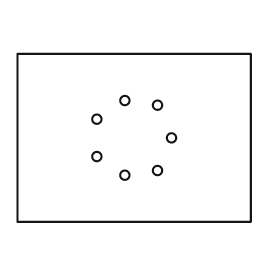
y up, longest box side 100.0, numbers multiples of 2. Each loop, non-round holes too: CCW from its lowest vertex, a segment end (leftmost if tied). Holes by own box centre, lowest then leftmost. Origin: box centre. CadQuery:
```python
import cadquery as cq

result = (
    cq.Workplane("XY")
    .moveTo(-50.0, -36.0)
    .lineTo(50.0, -36.0)
    .lineTo(50.0, 36.0)
    .lineTo(-50.0, 36.0)
    .close()
    .moveTo(-4.0, -16.0)
    .circle(2.0)
    .moveTo(10.0, -14.0)
    .circle(2.0)
    .moveTo(-16.0, -8.0)
    .circle(2.0)
    .moveTo(16.0, 0.0)
    .circle(2.0)
    .moveTo(-16.0, 8.0)
    .circle(2.0)
    .moveTo(10.0, 14.0)
    .circle(2.0)
    .moveTo(-4.0, 16.0)
    .circle(2.0)
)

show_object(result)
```